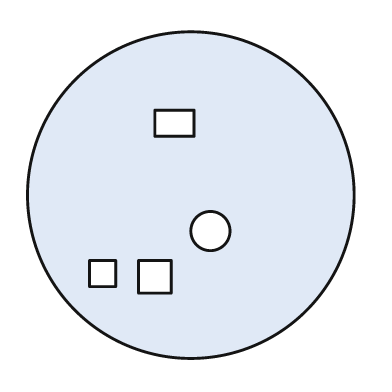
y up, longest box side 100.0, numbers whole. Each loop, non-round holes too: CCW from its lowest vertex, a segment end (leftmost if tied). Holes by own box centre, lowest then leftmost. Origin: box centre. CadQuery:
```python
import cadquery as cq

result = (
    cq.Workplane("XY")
    .moveTo(0.0, 0.0)
    .circle(50.0)
    .moveTo(-16.0, -30.0)
    .lineTo(-6.0, -30.0)
    .lineTo(-6.0, -20.0)
    .lineTo(-16.0, -20.0)
    .close()
    .moveTo(-31.0, -28.0)
    .lineTo(-23.0, -28.0)
    .lineTo(-23.0, -20.0)
    .lineTo(-31.0, -20.0)
    .close()
    .moveTo(6.0, -11.0)
    .circle(6.0)
    .moveTo(-11.0, 18.0)
    .lineTo(1.0, 18.0)
    .lineTo(1.0, 26.0)
    .lineTo(-11.0, 26.0)
    .close()
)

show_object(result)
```